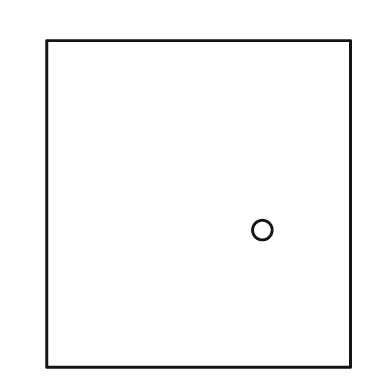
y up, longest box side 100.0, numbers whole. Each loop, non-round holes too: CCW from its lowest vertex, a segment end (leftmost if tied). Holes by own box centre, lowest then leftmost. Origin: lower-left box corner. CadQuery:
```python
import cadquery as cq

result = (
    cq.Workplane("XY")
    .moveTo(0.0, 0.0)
    .lineTo(93.0, 0.0)
    .lineTo(93.0, 100.0)
    .lineTo(0.0, 100.0)
    .close()
    .moveTo(66.0, 42.0)
    .circle(3.0)
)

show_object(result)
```